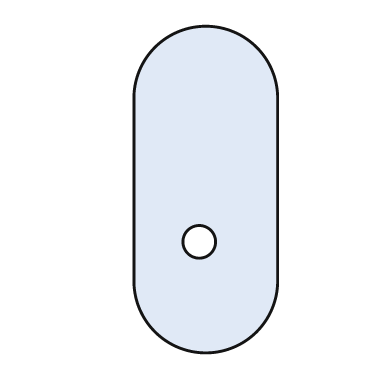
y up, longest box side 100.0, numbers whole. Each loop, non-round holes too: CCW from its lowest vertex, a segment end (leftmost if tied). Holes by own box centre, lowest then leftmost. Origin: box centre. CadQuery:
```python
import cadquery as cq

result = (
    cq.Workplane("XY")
    .moveTo(-22.0, -28.0)
    .threePointArc((0.0, -50.0), (22.0, -28.0))
    .lineTo(22.0, 28.0)
    .threePointArc((0.0, 50.0), (-22.0, 28.0))
    .close()
    .moveTo(-2.0, -16.0)
    .circle(5.0)
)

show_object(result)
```